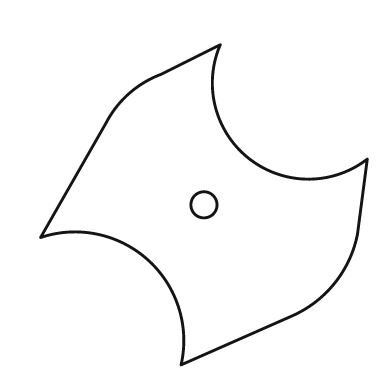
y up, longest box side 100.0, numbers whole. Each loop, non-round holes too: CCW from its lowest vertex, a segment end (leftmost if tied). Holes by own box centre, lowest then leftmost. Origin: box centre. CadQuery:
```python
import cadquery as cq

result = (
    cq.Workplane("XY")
    .moveTo(-7.0, -49.0)
    .lineTo(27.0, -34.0)
    .threePointArc((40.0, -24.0), (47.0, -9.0))
    .lineTo(50.0, 14.0)
    .threePointArc((14.0, 14.0), (5.0, 49.0))
    .lineTo(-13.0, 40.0)
    .threePointArc((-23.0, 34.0), (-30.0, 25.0))
    .lineTo(-50.0, -10.0)
    .threePointArc((-17.0, -17.0), (-7.0, -49.0))
    .close()
    .moveTo(0.0, 0.0)
    .circle(4.0)
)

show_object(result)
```